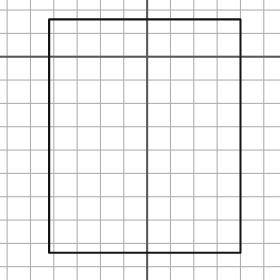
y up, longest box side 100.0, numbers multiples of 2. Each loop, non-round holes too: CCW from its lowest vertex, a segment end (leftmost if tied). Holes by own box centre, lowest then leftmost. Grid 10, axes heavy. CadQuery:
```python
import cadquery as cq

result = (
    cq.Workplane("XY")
    .moveTo(-42.0, -84.0)
    .lineTo(40.0, -84.0)
    .lineTo(40.0, 16.0)
    .lineTo(-42.0, 16.0)
    .close()
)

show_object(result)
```